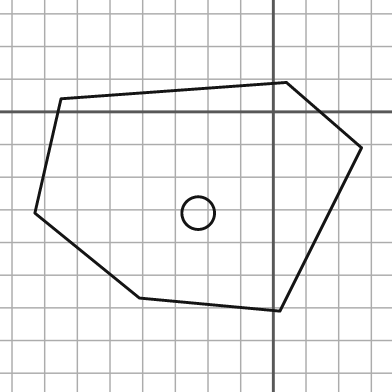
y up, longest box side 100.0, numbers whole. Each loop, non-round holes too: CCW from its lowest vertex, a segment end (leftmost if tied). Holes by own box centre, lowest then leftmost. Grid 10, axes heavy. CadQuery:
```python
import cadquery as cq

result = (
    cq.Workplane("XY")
    .moveTo(2.0, -61.0)
    .lineTo(27.0, -11.0)
    .lineTo(4.0, 9.0)
    .lineTo(-65.0, 4.0)
    .lineTo(-73.0, -31.0)
    .lineTo(-41.0, -57.0)
    .close()
    .moveTo(-23.0, -31.0)
    .circle(5.0)
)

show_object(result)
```